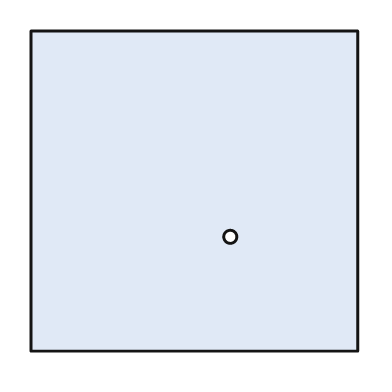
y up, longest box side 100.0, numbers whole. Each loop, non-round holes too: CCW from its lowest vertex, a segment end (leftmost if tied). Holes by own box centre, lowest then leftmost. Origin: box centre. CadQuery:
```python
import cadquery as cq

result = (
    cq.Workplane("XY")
    .moveTo(-50.0, -49.0)
    .lineTo(50.0, -49.0)
    .lineTo(50.0, 49.0)
    .lineTo(-50.0, 49.0)
    .close()
    .moveTo(11.0, -14.0)
    .circle(2.0)
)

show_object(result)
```